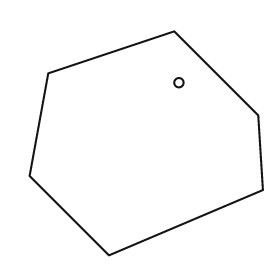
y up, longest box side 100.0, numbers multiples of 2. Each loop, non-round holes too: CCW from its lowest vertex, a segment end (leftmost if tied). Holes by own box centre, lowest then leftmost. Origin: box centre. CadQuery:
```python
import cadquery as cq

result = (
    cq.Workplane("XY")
    .moveTo(-16.0, -48.0)
    .lineTo(50.0, -20.0)
    .lineTo(48.0, 12.0)
    .lineTo(12.0, 48.0)
    .lineTo(-42.0, 30.0)
    .lineTo(-50.0, -14.0)
    .close()
    .moveTo(14.0, 26.0)
    .circle(2.0)
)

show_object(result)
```